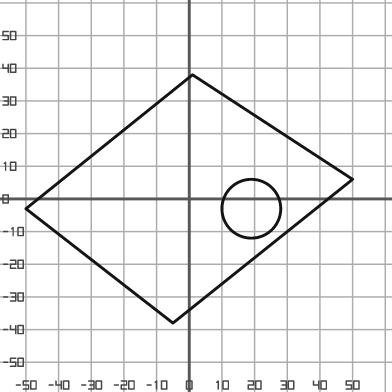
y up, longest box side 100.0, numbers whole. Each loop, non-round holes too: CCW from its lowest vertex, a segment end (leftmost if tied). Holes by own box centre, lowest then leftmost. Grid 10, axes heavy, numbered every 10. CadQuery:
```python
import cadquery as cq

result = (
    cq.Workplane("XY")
    .moveTo(-5.0, -38.0)
    .lineTo(50.0, 6.0)
    .lineTo(1.0, 38.0)
    .lineTo(-50.0, -3.0)
    .close()
    .moveTo(19.0, -3.0)
    .circle(9.0)
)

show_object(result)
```